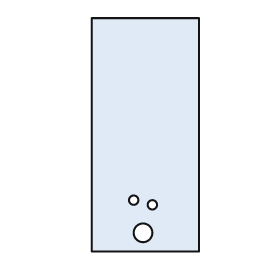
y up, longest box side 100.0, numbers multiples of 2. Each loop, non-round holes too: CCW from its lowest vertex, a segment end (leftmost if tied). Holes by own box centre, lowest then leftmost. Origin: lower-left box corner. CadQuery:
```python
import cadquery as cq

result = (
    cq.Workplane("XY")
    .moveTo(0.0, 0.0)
    .lineTo(46.0, 0.0)
    .lineTo(46.0, 100.0)
    .lineTo(0.0, 100.0)
    .close()
    .moveTo(22.0, 8.0)
    .circle(4.0)
    .moveTo(26.0, 20.0)
    .circle(2.0)
    .moveTo(18.0, 22.0)
    .circle(2.0)
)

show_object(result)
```